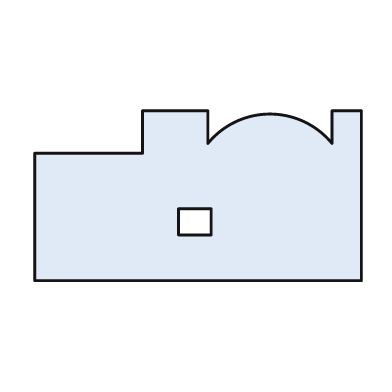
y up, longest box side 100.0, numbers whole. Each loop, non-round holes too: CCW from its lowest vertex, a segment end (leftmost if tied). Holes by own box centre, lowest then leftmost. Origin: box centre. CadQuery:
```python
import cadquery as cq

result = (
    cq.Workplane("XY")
    .moveTo(-50.0, -26.0)
    .lineTo(50.0, -26.0)
    .lineTo(50.0, 26.0)
    .lineTo(41.0, 26.0)
    .lineTo(41.0, 16.0)
    .threePointArc((22.0, 25.0), (3.0, 16.0))
    .lineTo(3.0, 26.0)
    .lineTo(-17.0, 26.0)
    .lineTo(-17.0, 13.0)
    .lineTo(-50.0, 13.0)
    .close()
    .moveTo(-6.0, -12.0)
    .lineTo(4.0, -12.0)
    .lineTo(4.0, -4.0)
    .lineTo(-6.0, -4.0)
    .close()
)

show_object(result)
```